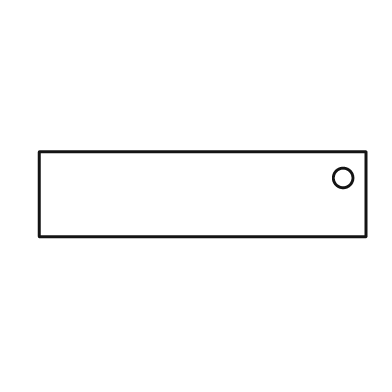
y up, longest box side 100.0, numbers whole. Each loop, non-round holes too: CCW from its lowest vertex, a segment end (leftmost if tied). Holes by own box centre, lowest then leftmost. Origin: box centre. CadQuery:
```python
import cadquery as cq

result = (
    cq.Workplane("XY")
    .moveTo(-50.0, -13.0)
    .lineTo(50.0, -13.0)
    .lineTo(50.0, 13.0)
    .lineTo(-50.0, 13.0)
    .close()
    .moveTo(43.0, 5.0)
    .circle(3.0)
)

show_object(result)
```